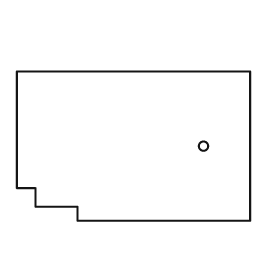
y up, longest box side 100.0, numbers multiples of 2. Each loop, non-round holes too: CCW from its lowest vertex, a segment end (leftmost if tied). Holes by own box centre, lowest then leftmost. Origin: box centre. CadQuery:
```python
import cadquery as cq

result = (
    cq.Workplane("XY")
    .moveTo(-24.0, -32.0)
    .lineTo(50.0, -32.0)
    .lineTo(50.0, 32.0)
    .lineTo(-50.0, 32.0)
    .lineTo(-50.0, -18.0)
    .lineTo(-42.0, -18.0)
    .lineTo(-42.0, -26.0)
    .lineTo(-24.0, -26.0)
    .close()
    .moveTo(30.0, 0.0)
    .circle(2.0)
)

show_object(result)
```